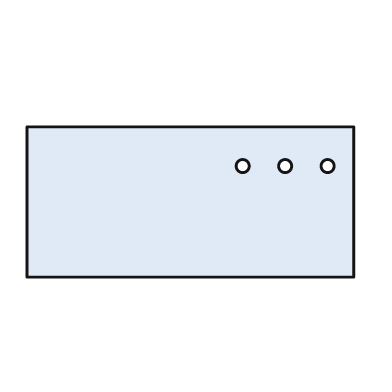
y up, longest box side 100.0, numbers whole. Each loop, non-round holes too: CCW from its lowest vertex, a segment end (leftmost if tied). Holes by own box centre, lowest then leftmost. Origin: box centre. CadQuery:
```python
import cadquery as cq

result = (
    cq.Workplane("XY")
    .moveTo(-50.0, -23.0)
    .lineTo(50.0, -23.0)
    .lineTo(50.0, 23.0)
    .lineTo(-50.0, 23.0)
    .close()
    .moveTo(16.0, 11.0)
    .circle(2.0)
    .moveTo(29.0, 11.0)
    .circle(2.0)
    .moveTo(42.0, 11.0)
    .circle(2.0)
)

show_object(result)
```